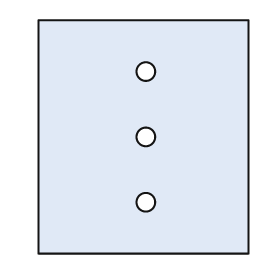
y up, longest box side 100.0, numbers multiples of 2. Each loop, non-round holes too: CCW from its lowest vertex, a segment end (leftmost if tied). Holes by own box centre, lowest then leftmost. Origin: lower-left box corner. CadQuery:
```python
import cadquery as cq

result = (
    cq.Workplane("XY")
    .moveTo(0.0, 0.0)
    .lineTo(90.0, 0.0)
    .lineTo(90.0, 100.0)
    .lineTo(0.0, 100.0)
    .close()
    .moveTo(46.0, 22.0)
    .circle(4.0)
    .moveTo(46.0, 50.0)
    .circle(4.0)
    .moveTo(46.0, 78.0)
    .circle(4.0)
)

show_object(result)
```